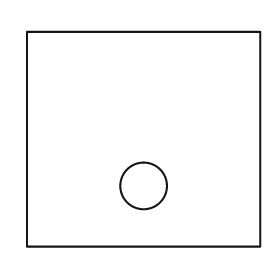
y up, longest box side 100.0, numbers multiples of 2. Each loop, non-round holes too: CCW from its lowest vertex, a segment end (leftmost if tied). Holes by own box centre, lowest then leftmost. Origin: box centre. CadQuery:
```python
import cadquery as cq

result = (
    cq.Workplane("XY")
    .moveTo(-50.0, -46.0)
    .lineTo(50.0, -46.0)
    .lineTo(50.0, 46.0)
    .lineTo(-50.0, 46.0)
    .close()
    .moveTo(0.0, -20.0)
    .circle(10.0)
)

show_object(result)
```